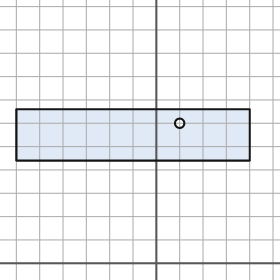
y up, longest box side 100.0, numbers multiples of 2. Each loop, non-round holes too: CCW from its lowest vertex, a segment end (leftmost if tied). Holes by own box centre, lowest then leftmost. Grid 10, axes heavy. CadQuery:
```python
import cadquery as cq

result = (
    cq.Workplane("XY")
    .moveTo(-60.0, 44.0)
    .lineTo(40.0, 44.0)
    .lineTo(40.0, 66.0)
    .lineTo(-60.0, 66.0)
    .close()
    .moveTo(10.0, 60.0)
    .circle(2.0)
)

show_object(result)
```